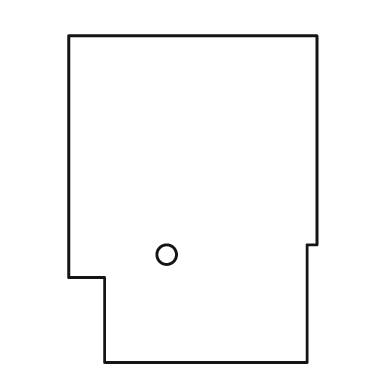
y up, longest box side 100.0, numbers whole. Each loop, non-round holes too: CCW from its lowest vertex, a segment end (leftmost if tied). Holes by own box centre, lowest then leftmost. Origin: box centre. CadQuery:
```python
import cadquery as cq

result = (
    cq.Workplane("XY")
    .moveTo(-27.0, -50.0)
    .lineTo(35.0, -50.0)
    .lineTo(35.0, -14.0)
    .lineTo(38.0, -14.0)
    .lineTo(38.0, 50.0)
    .lineTo(-38.0, 50.0)
    .lineTo(-38.0, -24.0)
    .lineTo(-27.0, -24.0)
    .close()
    .moveTo(-8.0, -17.0)
    .circle(3.0)
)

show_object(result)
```